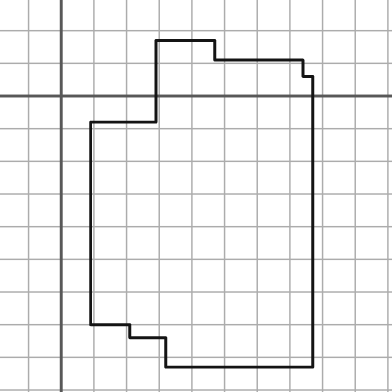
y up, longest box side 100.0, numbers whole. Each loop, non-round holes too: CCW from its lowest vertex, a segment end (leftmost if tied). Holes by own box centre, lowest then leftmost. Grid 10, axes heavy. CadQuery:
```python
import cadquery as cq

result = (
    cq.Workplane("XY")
    .moveTo(32.0, -83.0)
    .lineTo(77.0, -83.0)
    .lineTo(77.0, 6.0)
    .lineTo(74.0, 6.0)
    .lineTo(74.0, 11.0)
    .lineTo(47.0, 11.0)
    .lineTo(47.0, 17.0)
    .lineTo(29.0, 17.0)
    .lineTo(29.0, -8.0)
    .lineTo(9.0, -8.0)
    .lineTo(9.0, -70.0)
    .lineTo(21.0, -70.0)
    .lineTo(21.0, -74.0)
    .lineTo(32.0, -74.0)
    .close()
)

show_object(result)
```